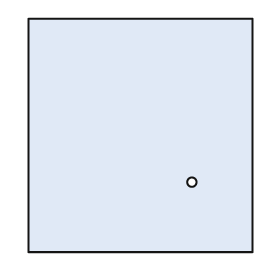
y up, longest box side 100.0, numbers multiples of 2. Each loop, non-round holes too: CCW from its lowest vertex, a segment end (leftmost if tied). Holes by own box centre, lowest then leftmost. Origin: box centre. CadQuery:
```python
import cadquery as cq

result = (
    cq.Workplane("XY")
    .moveTo(-48.0, -50.0)
    .lineTo(48.0, -50.0)
    .lineTo(48.0, 50.0)
    .lineTo(-48.0, 50.0)
    .close()
    .moveTo(22.0, -20.0)
    .circle(2.0)
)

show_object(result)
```